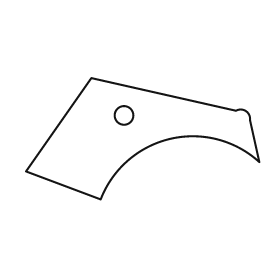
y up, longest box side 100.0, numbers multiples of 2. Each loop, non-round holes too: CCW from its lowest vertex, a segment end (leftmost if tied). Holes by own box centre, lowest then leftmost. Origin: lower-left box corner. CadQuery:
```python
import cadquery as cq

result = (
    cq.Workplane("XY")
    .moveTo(32.0, 0.0)
    .threePointArc((62.0, 26.0), (100.0, 16.0))
    .lineTo(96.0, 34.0)
    .threePointArc((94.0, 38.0), (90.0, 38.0))
    .lineTo(28.0, 52.0)
    .lineTo(0.0, 12.0)
    .close()
    .moveTo(42.0, 36.0)
    .circle(4.0)
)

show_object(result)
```